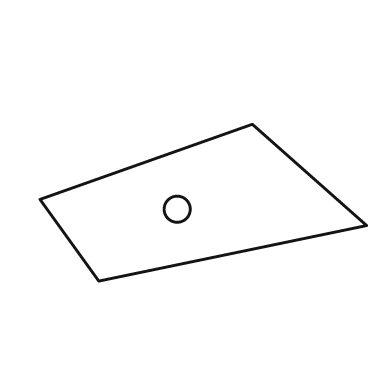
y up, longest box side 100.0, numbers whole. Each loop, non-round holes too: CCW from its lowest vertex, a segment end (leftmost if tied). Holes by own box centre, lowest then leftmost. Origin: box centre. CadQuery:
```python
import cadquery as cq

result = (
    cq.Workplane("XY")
    .moveTo(-32.0, -24.0)
    .lineTo(50.0, -7.0)
    .lineTo(15.0, 24.0)
    .lineTo(-50.0, 1.0)
    .close()
    .moveTo(-8.0, -2.0)
    .circle(4.0)
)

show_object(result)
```